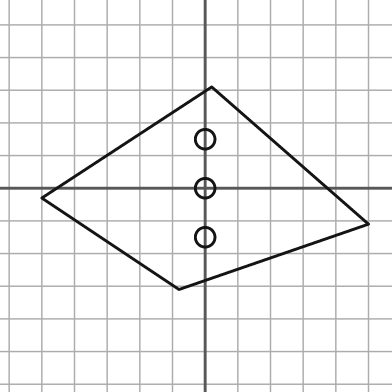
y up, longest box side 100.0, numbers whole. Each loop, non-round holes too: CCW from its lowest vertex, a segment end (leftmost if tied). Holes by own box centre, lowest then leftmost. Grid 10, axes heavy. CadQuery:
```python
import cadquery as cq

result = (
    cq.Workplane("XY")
    .moveTo(-8.0, -31.0)
    .lineTo(50.0, -11.0)
    .lineTo(2.0, 31.0)
    .lineTo(-50.0, -3.0)
    .close()
    .moveTo(0.0, -15.0)
    .circle(3.0)
    .moveTo(0.0, 0.0)
    .circle(3.0)
    .moveTo(0.0, 15.0)
    .circle(3.0)
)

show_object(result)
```